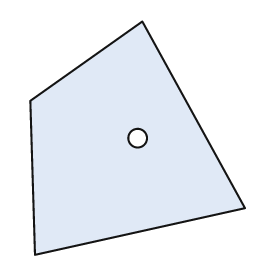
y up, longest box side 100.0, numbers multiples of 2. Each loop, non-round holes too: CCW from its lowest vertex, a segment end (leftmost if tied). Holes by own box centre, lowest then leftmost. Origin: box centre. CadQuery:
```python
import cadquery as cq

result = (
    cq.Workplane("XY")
    .moveTo(-44.0, -50.0)
    .lineTo(46.0, -30.0)
    .lineTo(2.0, 50.0)
    .lineTo(-46.0, 16.0)
    .close()
    .moveTo(0.0, 0.0)
    .circle(4.0)
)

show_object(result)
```